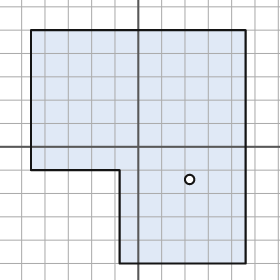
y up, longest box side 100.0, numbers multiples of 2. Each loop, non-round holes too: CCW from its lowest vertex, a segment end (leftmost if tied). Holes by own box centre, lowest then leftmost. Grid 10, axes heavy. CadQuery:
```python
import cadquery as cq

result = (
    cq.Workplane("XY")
    .moveTo(-8.0, -50.0)
    .lineTo(46.0, -50.0)
    .lineTo(46.0, 50.0)
    .lineTo(-46.0, 50.0)
    .lineTo(-46.0, -10.0)
    .lineTo(-8.0, -10.0)
    .close()
    .moveTo(22.0, -14.0)
    .circle(2.0)
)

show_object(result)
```